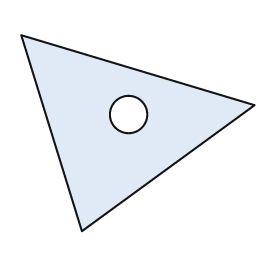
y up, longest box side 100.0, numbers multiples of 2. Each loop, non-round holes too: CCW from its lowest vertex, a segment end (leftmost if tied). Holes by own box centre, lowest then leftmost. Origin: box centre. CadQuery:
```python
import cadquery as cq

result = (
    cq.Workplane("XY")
    .moveTo(-24.0, -42.0)
    .lineTo(50.0, 12.0)
    .lineTo(-50.0, 42.0)
    .close()
    .moveTo(-4.0, 8.0)
    .circle(8.0)
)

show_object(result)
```